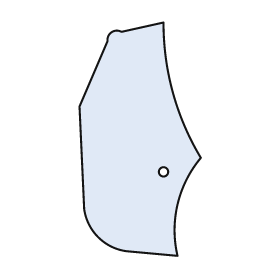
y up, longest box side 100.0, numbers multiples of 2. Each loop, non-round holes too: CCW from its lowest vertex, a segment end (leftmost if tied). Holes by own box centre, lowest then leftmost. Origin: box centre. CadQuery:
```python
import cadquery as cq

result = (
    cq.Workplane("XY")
    .moveTo(16.0, -50.0)
    .threePointArc((16.0, -28.0), (26.0, -8.0))
    .threePointArc((14.0, 20.0), (10.0, 50.0))
    .lineTo(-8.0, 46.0)
    .threePointArc((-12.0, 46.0), (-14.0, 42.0))
    .lineTo(-26.0, 14.0)
    .lineTo(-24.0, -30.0)
    .threePointArc((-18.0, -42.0), (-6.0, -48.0))
    .close()
    .moveTo(10.0, -14.0)
    .circle(2.0)
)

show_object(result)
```